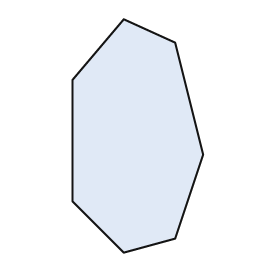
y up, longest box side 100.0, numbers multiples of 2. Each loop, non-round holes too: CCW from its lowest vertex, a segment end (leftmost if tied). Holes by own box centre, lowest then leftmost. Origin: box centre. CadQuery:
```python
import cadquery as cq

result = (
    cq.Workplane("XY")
    .moveTo(-6.0, -50.0)
    .lineTo(16.0, -44.0)
    .lineTo(28.0, -8.0)
    .lineTo(16.0, 40.0)
    .lineTo(-6.0, 50.0)
    .lineTo(-28.0, 24.0)
    .lineTo(-28.0, -28.0)
    .close()
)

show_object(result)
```